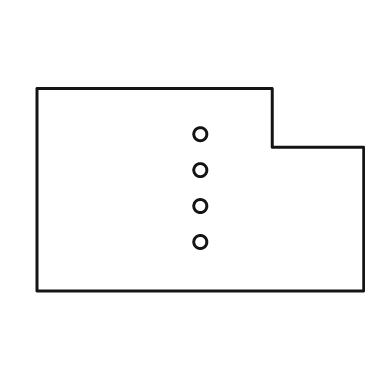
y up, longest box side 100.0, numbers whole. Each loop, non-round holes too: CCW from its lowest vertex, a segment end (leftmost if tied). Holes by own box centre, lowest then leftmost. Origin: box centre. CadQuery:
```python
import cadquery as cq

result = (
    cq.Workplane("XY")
    .moveTo(-50.0, -31.0)
    .lineTo(50.0, -31.0)
    .lineTo(50.0, 13.0)
    .lineTo(22.0, 13.0)
    .lineTo(22.0, 31.0)
    .lineTo(-50.0, 31.0)
    .close()
    .moveTo(0.0, -16.0)
    .circle(2.0)
    .moveTo(0.0, -5.0)
    .circle(2.0)
    .moveTo(0.0, 6.0)
    .circle(2.0)
    .moveTo(0.0, 17.0)
    .circle(2.0)
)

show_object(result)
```